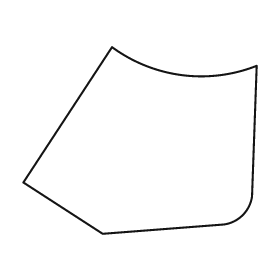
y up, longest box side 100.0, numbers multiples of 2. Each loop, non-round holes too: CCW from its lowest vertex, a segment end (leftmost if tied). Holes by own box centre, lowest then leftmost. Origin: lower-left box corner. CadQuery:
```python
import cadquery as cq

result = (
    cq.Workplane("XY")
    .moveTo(34.0, 0.0)
    .lineTo(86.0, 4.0)
    .threePointArc((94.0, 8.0), (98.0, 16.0))
    .lineTo(100.0, 72.0)
    .threePointArc((68.0, 68.0), (38.0, 80.0))
    .lineTo(0.0, 22.0)
    .close()
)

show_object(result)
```